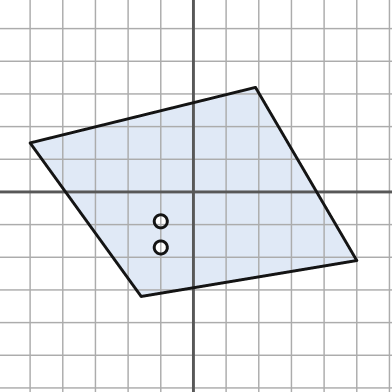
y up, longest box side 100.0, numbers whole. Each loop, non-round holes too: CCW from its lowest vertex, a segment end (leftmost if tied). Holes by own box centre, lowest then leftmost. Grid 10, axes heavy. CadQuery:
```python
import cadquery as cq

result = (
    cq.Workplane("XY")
    .moveTo(-16.0, -32.0)
    .lineTo(50.0, -21.0)
    .lineTo(19.0, 32.0)
    .lineTo(-50.0, 15.0)
    .close()
    .moveTo(-10.0, -17.0)
    .circle(2.0)
    .moveTo(-10.0, -9.0)
    .circle(2.0)
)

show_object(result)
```